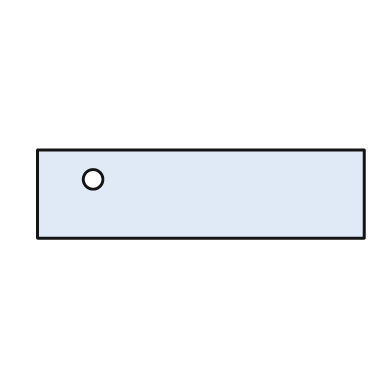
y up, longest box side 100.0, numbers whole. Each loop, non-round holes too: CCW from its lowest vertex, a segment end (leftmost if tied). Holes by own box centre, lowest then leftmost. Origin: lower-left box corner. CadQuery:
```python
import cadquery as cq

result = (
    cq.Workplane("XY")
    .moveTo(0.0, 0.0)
    .lineTo(100.0, 0.0)
    .lineTo(100.0, 27.0)
    .lineTo(0.0, 27.0)
    .close()
    .moveTo(17.0, 18.0)
    .circle(3.0)
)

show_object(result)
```